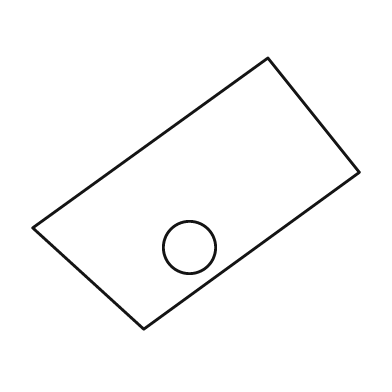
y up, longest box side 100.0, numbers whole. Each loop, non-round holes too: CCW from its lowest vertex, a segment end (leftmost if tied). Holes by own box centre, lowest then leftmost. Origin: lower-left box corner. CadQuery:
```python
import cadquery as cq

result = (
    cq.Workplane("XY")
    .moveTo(34.0, 0.0)
    .lineTo(100.0, 48.0)
    .lineTo(72.0, 83.0)
    .lineTo(0.0, 31.0)
    .close()
    .moveTo(48.0, 25.0)
    .circle(8.0)
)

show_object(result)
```